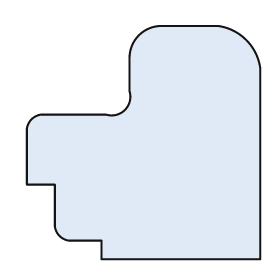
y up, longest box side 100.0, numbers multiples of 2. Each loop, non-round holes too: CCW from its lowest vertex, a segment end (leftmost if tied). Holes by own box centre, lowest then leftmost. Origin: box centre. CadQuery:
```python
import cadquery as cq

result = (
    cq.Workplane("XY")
    .moveTo(-18.0, -50.0)
    .lineTo(50.0, -50.0)
    .lineTo(50.0, 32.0)
    .threePointArc((44.0, 44.0), (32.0, 50.0))
    .lineTo(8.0, 50.0)
    .threePointArc((-2.0, 46.0), (-6.0, 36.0))
    .lineTo(-6.0, 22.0)
    .threePointArc((-8.0, 14.0), (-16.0, 12.0))
    .lineTo(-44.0, 12.0)
    .threePointArc((-48.0, 10.0), (-50.0, 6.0))
    .lineTo(-50.0, -18.0)
    .lineTo(-38.0, -18.0)
    .lineTo(-38.0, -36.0)
    .threePointArc((-36.0, -40.0), (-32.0, -42.0))
    .lineTo(-18.0, -42.0)
    .close()
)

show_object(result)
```